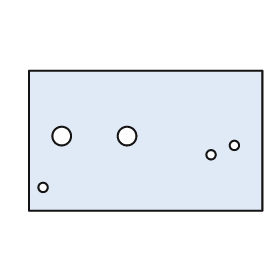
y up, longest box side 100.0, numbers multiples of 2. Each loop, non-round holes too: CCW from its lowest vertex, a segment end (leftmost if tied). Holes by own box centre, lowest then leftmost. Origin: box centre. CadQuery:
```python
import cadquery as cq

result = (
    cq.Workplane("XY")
    .moveTo(-50.0, -30.0)
    .lineTo(50.0, -30.0)
    .lineTo(50.0, 30.0)
    .lineTo(-50.0, 30.0)
    .close()
    .moveTo(-44.0, -20.0)
    .circle(2.0)
    .moveTo(28.0, -6.0)
    .circle(2.0)
    .moveTo(38.0, -2.0)
    .circle(2.0)
    .moveTo(-36.0, 2.0)
    .circle(4.0)
    .moveTo(-8.0, 2.0)
    .circle(4.0)
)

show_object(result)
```